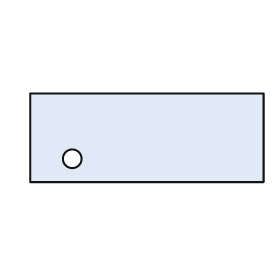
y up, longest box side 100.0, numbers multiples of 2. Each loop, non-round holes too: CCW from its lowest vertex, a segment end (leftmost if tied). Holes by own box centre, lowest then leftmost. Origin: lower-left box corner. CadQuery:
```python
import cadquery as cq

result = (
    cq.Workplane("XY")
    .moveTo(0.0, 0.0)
    .lineTo(100.0, 0.0)
    .lineTo(100.0, 38.0)
    .lineTo(0.0, 38.0)
    .close()
    .moveTo(18.0, 10.0)
    .circle(4.0)
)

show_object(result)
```